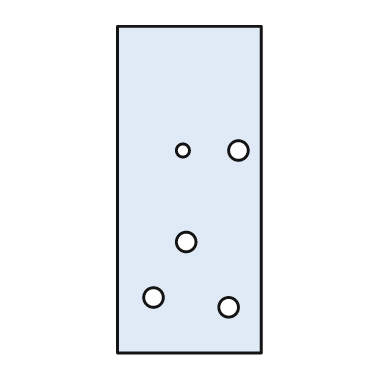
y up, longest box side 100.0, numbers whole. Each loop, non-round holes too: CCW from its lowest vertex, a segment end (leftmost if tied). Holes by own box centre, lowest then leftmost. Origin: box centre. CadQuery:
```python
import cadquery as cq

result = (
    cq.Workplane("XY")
    .moveTo(-22.0, -50.0)
    .lineTo(22.0, -50.0)
    .lineTo(22.0, 50.0)
    .lineTo(-22.0, 50.0)
    .close()
    .moveTo(12.0, -36.0)
    .circle(3.0)
    .moveTo(-11.0, -33.0)
    .circle(3.0)
    .moveTo(-1.0, -16.0)
    .circle(3.0)
    .moveTo(-2.0, 12.0)
    .circle(2.0)
    .moveTo(15.0, 12.0)
    .circle(3.0)
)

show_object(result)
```